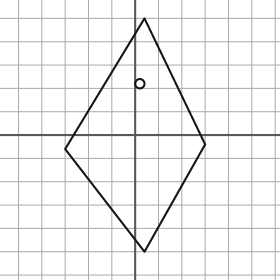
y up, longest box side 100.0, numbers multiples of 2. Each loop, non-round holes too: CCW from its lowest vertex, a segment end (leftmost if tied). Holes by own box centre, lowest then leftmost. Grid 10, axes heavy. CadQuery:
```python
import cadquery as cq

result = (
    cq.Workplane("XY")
    .moveTo(4.0, -50.0)
    .lineTo(30.0, -4.0)
    .lineTo(4.0, 50.0)
    .lineTo(-30.0, -6.0)
    .close()
    .moveTo(2.0, 22.0)
    .circle(2.0)
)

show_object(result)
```